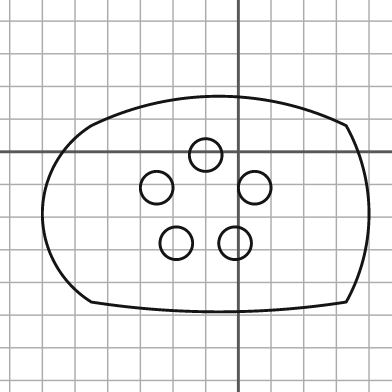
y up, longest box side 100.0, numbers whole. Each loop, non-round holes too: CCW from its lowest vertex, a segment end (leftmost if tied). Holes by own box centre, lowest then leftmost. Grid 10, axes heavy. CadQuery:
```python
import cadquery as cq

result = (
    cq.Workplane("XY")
    .moveTo(-45.0, -46.0)
    .threePointArc((-6.0, -49.0), (33.0, -46.0))
    .threePointArc((40.0, -19.0), (33.0, 8.0))
    .threePointArc((-6.0, 17.0), (-45.0, 8.0))
    .threePointArc((-60.0, -19.0), (-45.0, -46.0))
    .close()
    .moveTo(-19.0, -28.0)
    .circle(5.0)
    .moveTo(-1.0, -28.0)
    .circle(5.0)
    .moveTo(-25.0, -11.0)
    .circle(5.0)
    .moveTo(5.0, -11.0)
    .circle(5.0)
    .moveTo(-10.0, -1.0)
    .circle(5.0)
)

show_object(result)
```